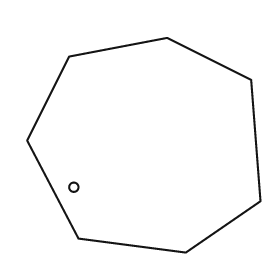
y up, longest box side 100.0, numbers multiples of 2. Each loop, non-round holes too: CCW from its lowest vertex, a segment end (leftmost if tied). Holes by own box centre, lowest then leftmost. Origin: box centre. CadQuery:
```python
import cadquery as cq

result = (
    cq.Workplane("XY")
    .moveTo(18.0, -46.0)
    .lineTo(50.0, -24.0)
    .lineTo(46.0, 28.0)
    .lineTo(10.0, 46.0)
    .lineTo(-32.0, 38.0)
    .lineTo(-50.0, 2.0)
    .lineTo(-28.0, -40.0)
    .close()
    .moveTo(-30.0, -18.0)
    .circle(2.0)
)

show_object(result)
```